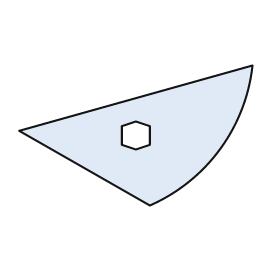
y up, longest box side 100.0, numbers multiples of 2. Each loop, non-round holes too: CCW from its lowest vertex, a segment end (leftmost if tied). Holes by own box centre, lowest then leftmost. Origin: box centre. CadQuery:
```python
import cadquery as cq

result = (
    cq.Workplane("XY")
    .moveTo(6.0, -30.0)
    .threePointArc((36.0, -6.0), (50.0, 30.0))
    .lineTo(-50.0, 2.0)
    .close()
    .moveTo(0.0, -6.0)
    .lineTo(6.0, -4.0)
    .lineTo(6.0, 4.0)
    .lineTo(0.0, 6.0)
    .lineTo(-6.0, 4.0)
    .lineTo(-6.0, -4.0)
    .close()
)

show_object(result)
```